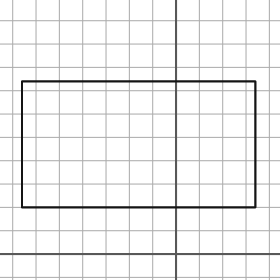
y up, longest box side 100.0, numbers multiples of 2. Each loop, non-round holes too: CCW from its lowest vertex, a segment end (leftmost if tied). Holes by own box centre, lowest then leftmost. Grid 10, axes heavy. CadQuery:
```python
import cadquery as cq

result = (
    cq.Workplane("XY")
    .moveTo(-66.0, 20.0)
    .lineTo(34.0, 20.0)
    .lineTo(34.0, 74.0)
    .lineTo(-66.0, 74.0)
    .close()
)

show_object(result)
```